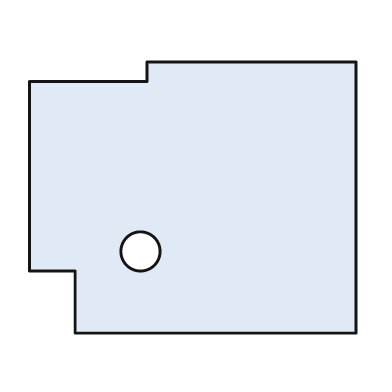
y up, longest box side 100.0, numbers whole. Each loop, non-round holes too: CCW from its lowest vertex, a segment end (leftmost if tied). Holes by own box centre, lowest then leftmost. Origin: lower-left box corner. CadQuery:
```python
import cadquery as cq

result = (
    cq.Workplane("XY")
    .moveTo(14.0, 0.0)
    .lineTo(100.0, 0.0)
    .lineTo(100.0, 83.0)
    .lineTo(36.0, 83.0)
    .lineTo(36.0, 77.0)
    .lineTo(0.0, 77.0)
    .lineTo(0.0, 19.0)
    .lineTo(14.0, 19.0)
    .close()
    .moveTo(34.0, 25.0)
    .circle(6.0)
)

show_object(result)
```